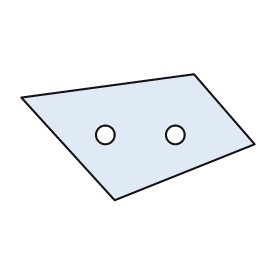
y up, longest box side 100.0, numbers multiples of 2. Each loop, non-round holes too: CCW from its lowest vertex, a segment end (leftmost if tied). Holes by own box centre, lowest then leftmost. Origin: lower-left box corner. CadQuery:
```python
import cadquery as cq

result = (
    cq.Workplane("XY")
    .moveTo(40.0, 0.0)
    .lineTo(100.0, 24.0)
    .lineTo(74.0, 54.0)
    .lineTo(0.0, 44.0)
    .close()
    .moveTo(36.0, 28.0)
    .circle(4.0)
    .moveTo(66.0, 28.0)
    .circle(4.0)
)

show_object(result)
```